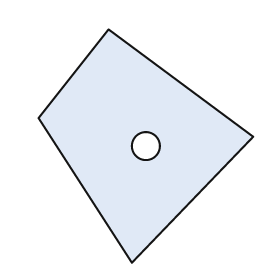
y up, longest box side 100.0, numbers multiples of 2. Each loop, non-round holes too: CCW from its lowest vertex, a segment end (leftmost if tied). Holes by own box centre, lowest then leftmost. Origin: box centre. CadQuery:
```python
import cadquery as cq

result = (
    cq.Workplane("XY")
    .moveTo(-6.0, -50.0)
    .lineTo(46.0, 4.0)
    .lineTo(-16.0, 50.0)
    .lineTo(-46.0, 12.0)
    .close()
    .moveTo(0.0, 0.0)
    .circle(6.0)
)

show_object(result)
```